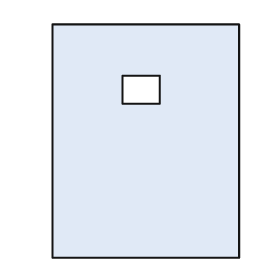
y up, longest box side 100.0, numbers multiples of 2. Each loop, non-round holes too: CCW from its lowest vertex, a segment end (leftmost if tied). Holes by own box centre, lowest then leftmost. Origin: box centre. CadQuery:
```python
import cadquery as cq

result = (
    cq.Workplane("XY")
    .moveTo(-40.0, -50.0)
    .lineTo(40.0, -50.0)
    .lineTo(40.0, 50.0)
    .lineTo(-40.0, 50.0)
    .close()
    .moveTo(-10.0, 16.0)
    .lineTo(6.0, 16.0)
    .lineTo(6.0, 28.0)
    .lineTo(-10.0, 28.0)
    .close()
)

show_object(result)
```